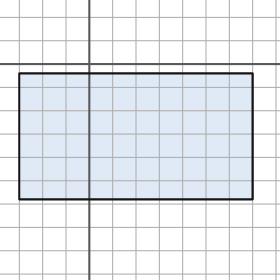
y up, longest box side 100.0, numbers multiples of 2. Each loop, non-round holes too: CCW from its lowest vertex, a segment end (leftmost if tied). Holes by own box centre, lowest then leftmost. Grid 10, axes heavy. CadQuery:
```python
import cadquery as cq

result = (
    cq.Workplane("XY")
    .moveTo(-30.0, -58.0)
    .lineTo(70.0, -58.0)
    .lineTo(70.0, -4.0)
    .lineTo(-30.0, -4.0)
    .close()
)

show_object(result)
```